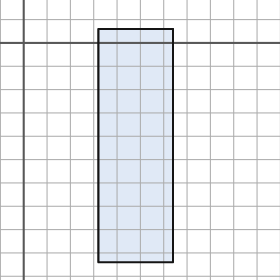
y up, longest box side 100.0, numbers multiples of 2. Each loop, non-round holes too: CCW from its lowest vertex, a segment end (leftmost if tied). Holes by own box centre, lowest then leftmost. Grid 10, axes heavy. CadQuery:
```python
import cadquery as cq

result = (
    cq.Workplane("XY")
    .moveTo(32.0, -94.0)
    .lineTo(64.0, -94.0)
    .lineTo(64.0, 6.0)
    .lineTo(32.0, 6.0)
    .close()
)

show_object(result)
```